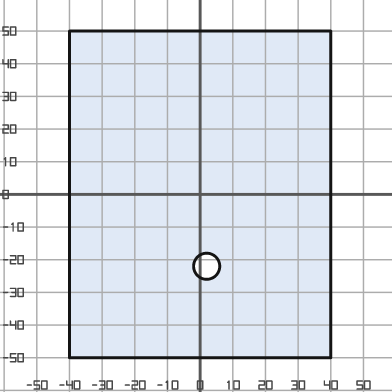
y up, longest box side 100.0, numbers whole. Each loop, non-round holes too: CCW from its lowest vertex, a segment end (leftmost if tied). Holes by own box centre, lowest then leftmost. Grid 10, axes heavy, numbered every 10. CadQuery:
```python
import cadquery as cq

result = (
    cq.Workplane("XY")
    .moveTo(-40.0, -50.0)
    .lineTo(40.0, -50.0)
    .lineTo(40.0, 50.0)
    .lineTo(-40.0, 50.0)
    .close()
    .moveTo(2.0, -22.0)
    .circle(4.0)
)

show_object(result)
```